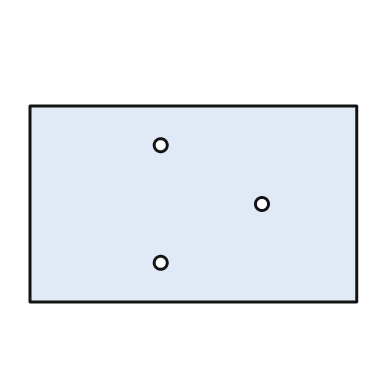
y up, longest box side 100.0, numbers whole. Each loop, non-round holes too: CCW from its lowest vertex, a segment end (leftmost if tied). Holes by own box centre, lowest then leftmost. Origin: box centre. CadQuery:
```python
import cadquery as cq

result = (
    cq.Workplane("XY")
    .moveTo(-50.0, -30.0)
    .lineTo(50.0, -30.0)
    .lineTo(50.0, 30.0)
    .lineTo(-50.0, 30.0)
    .close()
    .moveTo(-10.0, -18.0)
    .circle(2.0)
    .moveTo(21.0, 0.0)
    .circle(2.0)
    .moveTo(-10.0, 18.0)
    .circle(2.0)
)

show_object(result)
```